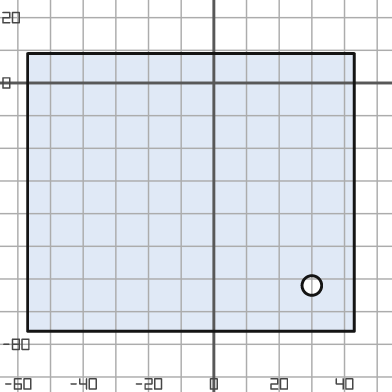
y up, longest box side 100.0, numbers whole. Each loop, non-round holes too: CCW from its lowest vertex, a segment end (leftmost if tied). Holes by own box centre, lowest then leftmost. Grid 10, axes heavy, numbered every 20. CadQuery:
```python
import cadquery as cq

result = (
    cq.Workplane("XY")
    .moveTo(-57.0, -76.0)
    .lineTo(43.0, -76.0)
    .lineTo(43.0, 9.0)
    .lineTo(-57.0, 9.0)
    .close()
    .moveTo(30.0, -62.0)
    .circle(3.0)
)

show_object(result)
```